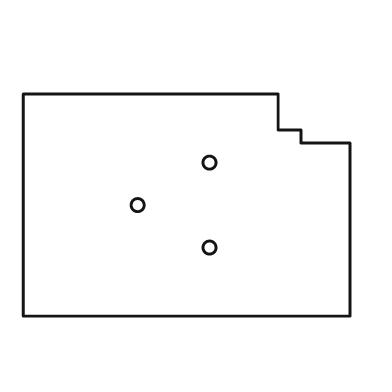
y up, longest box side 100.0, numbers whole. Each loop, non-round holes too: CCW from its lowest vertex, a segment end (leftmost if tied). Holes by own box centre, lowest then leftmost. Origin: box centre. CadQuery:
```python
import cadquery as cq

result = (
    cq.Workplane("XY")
    .moveTo(-50.0, -34.0)
    .lineTo(50.0, -34.0)
    .lineTo(50.0, 19.0)
    .lineTo(35.0, 19.0)
    .lineTo(35.0, 23.0)
    .lineTo(28.0, 23.0)
    .lineTo(28.0, 34.0)
    .lineTo(-50.0, 34.0)
    .close()
    .moveTo(7.0, -13.0)
    .circle(2.0)
    .moveTo(-15.0, 0.0)
    .circle(2.0)
    .moveTo(7.0, 13.0)
    .circle(2.0)
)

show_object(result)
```